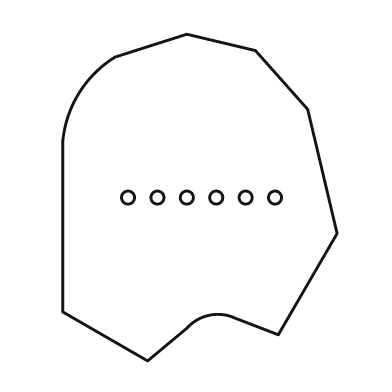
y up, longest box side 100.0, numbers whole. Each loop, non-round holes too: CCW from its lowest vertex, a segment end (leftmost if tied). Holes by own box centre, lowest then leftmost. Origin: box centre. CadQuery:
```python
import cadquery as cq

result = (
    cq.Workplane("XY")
    .moveTo(-16.0, -50.0)
    .lineTo(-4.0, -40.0)
    .threePointArc((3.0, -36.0), (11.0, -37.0))
    .lineTo(24.0, -42.0)
    .lineTo(42.0, -11.0)
    .lineTo(33.0, 27.0)
    .lineTo(17.0, 45.0)
    .lineTo(-4.0, 50.0)
    .lineTo(-26.0, 43.0)
    .threePointArc((-37.0, 32.0), (-42.0, 17.0))
    .lineTo(-42.0, -35.0)
    .close()
    .moveTo(-22.0, 0.0)
    .circle(2.0)
    .moveTo(-13.0, 0.0)
    .circle(2.0)
    .moveTo(-4.0, 0.0)
    .circle(2.0)
    .moveTo(5.0, 0.0)
    .circle(2.0)
    .moveTo(14.0, 0.0)
    .circle(2.0)
    .moveTo(23.0, 0.0)
    .circle(2.0)
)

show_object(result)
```